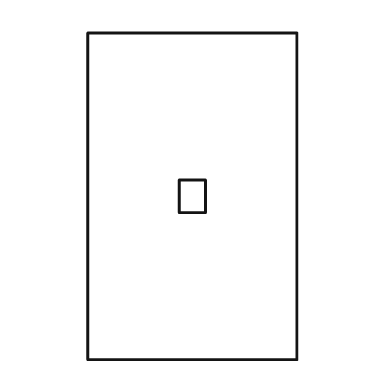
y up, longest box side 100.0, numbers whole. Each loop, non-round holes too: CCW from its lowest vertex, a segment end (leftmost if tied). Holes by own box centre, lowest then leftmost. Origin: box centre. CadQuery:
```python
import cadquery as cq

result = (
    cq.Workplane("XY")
    .moveTo(-32.0, -50.0)
    .lineTo(32.0, -50.0)
    .lineTo(32.0, 50.0)
    .lineTo(-32.0, 50.0)
    .close()
    .moveTo(-4.0, -5.0)
    .lineTo(4.0, -5.0)
    .lineTo(4.0, 5.0)
    .lineTo(-4.0, 5.0)
    .close()
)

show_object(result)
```